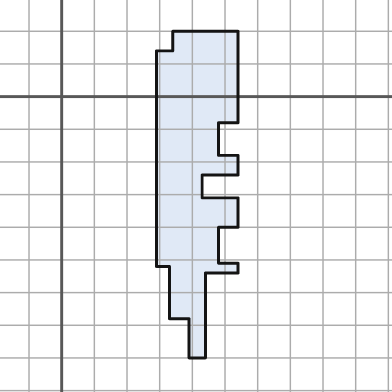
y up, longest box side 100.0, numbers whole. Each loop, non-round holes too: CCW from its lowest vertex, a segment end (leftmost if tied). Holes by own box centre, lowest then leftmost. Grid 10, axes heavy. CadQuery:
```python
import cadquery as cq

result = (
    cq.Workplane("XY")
    .moveTo(39.0, -80.0)
    .lineTo(44.0, -80.0)
    .lineTo(44.0, -54.0)
    .lineTo(54.0, -54.0)
    .lineTo(54.0, -51.0)
    .lineTo(48.0, -51.0)
    .lineTo(48.0, -40.0)
    .lineTo(54.0, -40.0)
    .lineTo(54.0, -31.0)
    .lineTo(43.0, -31.0)
    .lineTo(43.0, -24.0)
    .lineTo(54.0, -24.0)
    .lineTo(54.0, -18.0)
    .lineTo(48.0, -18.0)
    .lineTo(48.0, -8.0)
    .lineTo(54.0, -8.0)
    .lineTo(54.0, 20.0)
    .lineTo(34.0, 20.0)
    .lineTo(34.0, 14.0)
    .lineTo(29.0, 14.0)
    .lineTo(29.0, -52.0)
    .lineTo(33.0, -52.0)
    .lineTo(33.0, -68.0)
    .lineTo(39.0, -68.0)
    .close()
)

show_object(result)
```